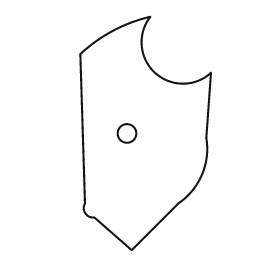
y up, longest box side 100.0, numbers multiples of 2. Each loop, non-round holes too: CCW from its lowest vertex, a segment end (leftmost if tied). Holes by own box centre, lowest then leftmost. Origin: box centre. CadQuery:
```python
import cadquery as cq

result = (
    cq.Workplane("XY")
    .moveTo(-6.0, -50.0)
    .lineTo(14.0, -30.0)
    .threePointArc((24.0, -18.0), (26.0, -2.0))
    .lineTo(28.0, 26.0)
    .threePointArc((4.0, 26.0), (2.0, 50.0))
    .threePointArc((-14.0, 44.0), (-28.0, 34.0))
    .lineTo(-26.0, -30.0)
    .threePointArc((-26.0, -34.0), (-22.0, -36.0))
    .close()
    .moveTo(-8.0, 0.0)
    .circle(4.0)
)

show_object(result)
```